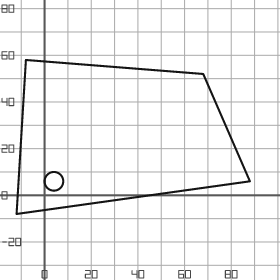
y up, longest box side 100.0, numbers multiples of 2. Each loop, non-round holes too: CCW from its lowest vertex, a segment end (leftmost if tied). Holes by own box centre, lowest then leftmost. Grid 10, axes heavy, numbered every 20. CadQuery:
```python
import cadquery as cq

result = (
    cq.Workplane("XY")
    .moveTo(-12.0, -8.0)
    .lineTo(88.0, 6.0)
    .lineTo(68.0, 52.0)
    .lineTo(-8.0, 58.0)
    .close()
    .moveTo(4.0, 6.0)
    .circle(4.0)
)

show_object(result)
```